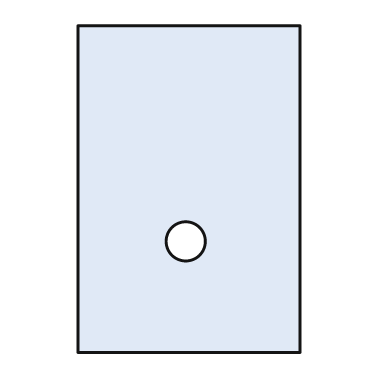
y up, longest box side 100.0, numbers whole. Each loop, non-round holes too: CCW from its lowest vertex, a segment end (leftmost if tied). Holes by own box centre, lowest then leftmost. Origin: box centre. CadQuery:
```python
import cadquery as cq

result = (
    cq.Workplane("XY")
    .moveTo(-34.0, -50.0)
    .lineTo(34.0, -50.0)
    .lineTo(34.0, 50.0)
    .lineTo(-34.0, 50.0)
    .close()
    .moveTo(-1.0, -16.0)
    .circle(6.0)
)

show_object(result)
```